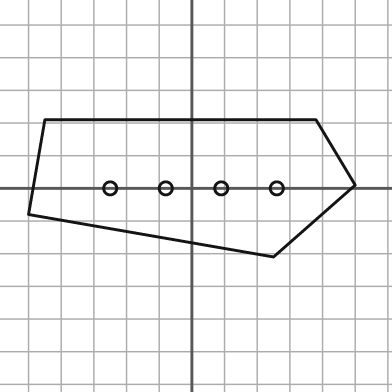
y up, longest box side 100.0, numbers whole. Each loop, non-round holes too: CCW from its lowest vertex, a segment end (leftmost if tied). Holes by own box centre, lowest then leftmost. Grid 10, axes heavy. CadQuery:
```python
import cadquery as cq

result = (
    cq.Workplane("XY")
    .moveTo(25.0, -21.0)
    .lineTo(50.0, 1.0)
    .lineTo(38.0, 21.0)
    .lineTo(-45.0, 21.0)
    .lineTo(-50.0, -8.0)
    .close()
    .moveTo(-25.0, 0.0)
    .circle(2.0)
    .moveTo(-8.0, 0.0)
    .circle(2.0)
    .moveTo(9.0, 0.0)
    .circle(2.0)
    .moveTo(26.0, 0.0)
    .circle(2.0)
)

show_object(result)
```